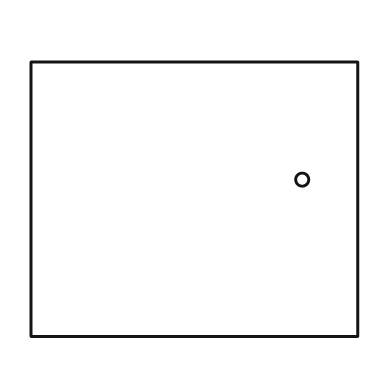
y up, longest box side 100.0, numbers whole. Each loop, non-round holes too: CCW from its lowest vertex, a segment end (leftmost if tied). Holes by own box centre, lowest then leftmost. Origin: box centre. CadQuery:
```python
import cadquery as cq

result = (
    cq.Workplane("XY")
    .moveTo(-50.0, -42.0)
    .lineTo(50.0, -42.0)
    .lineTo(50.0, 42.0)
    .lineTo(-50.0, 42.0)
    .close()
    .moveTo(33.0, 6.0)
    .circle(2.0)
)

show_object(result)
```